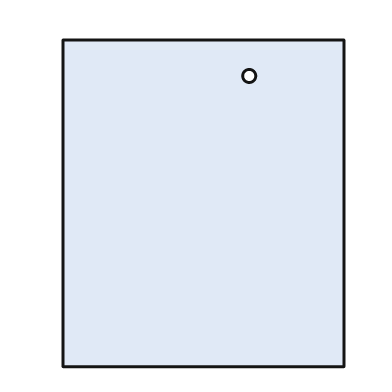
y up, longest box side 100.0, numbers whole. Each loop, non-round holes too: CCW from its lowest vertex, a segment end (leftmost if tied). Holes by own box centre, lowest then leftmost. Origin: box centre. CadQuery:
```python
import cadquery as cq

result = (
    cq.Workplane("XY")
    .moveTo(-43.0, -50.0)
    .lineTo(43.0, -50.0)
    .lineTo(43.0, 50.0)
    .lineTo(-43.0, 50.0)
    .close()
    .moveTo(14.0, 39.0)
    .circle(2.0)
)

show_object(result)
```